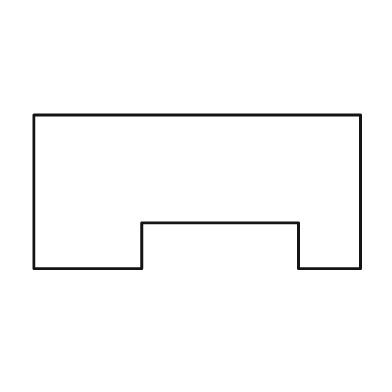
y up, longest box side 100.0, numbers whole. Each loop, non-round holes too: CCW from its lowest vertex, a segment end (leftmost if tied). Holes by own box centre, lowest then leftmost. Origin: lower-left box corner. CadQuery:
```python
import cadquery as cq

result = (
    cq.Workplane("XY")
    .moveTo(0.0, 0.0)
    .lineTo(33.0, 0.0)
    .lineTo(33.0, 14.0)
    .lineTo(81.0, 14.0)
    .lineTo(81.0, 0.0)
    .lineTo(100.0, 0.0)
    .lineTo(100.0, 47.0)
    .lineTo(0.0, 47.0)
    .close()
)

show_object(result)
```